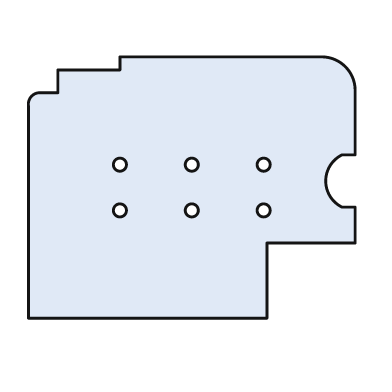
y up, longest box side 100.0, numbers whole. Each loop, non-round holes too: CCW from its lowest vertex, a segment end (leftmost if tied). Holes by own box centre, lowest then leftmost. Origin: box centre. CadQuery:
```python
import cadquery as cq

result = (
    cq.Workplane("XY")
    .moveTo(-50.0, -40.0)
    .lineTo(23.0, -40.0)
    .lineTo(23.0, -17.0)
    .lineTo(50.0, -17.0)
    .lineTo(50.0, -6.0)
    .lineTo(46.0, -6.0)
    .threePointArc((41.0, 2.0), (46.0, 10.0))
    .lineTo(50.0, 10.0)
    .lineTo(50.0, 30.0)
    .threePointArc((47.0, 37.0), (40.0, 40.0))
    .lineTo(-22.0, 40.0)
    .lineTo(-22.0, 36.0)
    .lineTo(-41.0, 36.0)
    .lineTo(-41.0, 29.0)
    .lineTo(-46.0, 29.0)
    .threePointArc((-49.0, 28.0), (-50.0, 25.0))
    .close()
    .moveTo(-22.0, -7.0)
    .circle(2.0)
    .moveTo(0.0, -7.0)
    .circle(2.0)
    .moveTo(22.0, -7.0)
    .circle(2.0)
    .moveTo(-22.0, 7.0)
    .circle(2.0)
    .moveTo(0.0, 7.0)
    .circle(2.0)
    .moveTo(22.0, 7.0)
    .circle(2.0)
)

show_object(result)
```